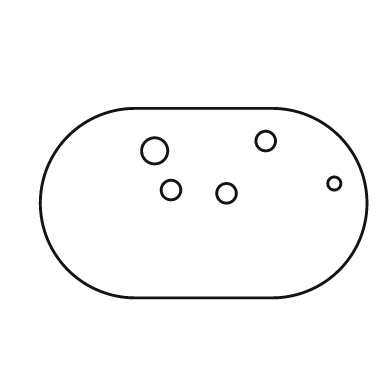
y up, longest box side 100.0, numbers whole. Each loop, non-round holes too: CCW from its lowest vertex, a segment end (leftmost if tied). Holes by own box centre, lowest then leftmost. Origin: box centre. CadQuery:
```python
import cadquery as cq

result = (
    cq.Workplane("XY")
    .moveTo(-21.0, -29.0)
    .lineTo(21.0, -29.0)
    .threePointArc((50.0, 0.0), (21.0, 29.0))
    .lineTo(-21.0, 29.0)
    .threePointArc((-50.0, 0.0), (-21.0, -29.0))
    .close()
    .moveTo(7.0, 3.0)
    .circle(3.0)
    .moveTo(-10.0, 4.0)
    .circle(3.0)
    .moveTo(40.0, 6.0)
    .circle(2.0)
    .moveTo(-15.0, 16.0)
    .circle(4.0)
    .moveTo(19.0, 19.0)
    .circle(3.0)
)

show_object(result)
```